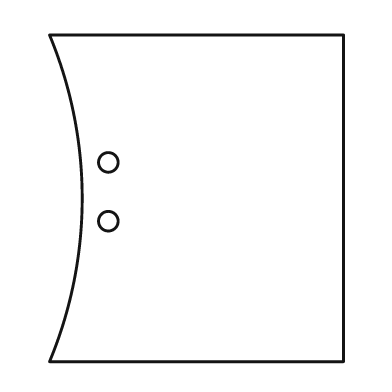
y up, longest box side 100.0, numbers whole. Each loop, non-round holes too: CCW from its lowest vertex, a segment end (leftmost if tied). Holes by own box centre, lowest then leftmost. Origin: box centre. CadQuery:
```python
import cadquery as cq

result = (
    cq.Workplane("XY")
    .moveTo(-45.0, -50.0)
    .lineTo(45.0, -50.0)
    .lineTo(45.0, 50.0)
    .lineTo(-45.0, 50.0)
    .threePointArc((-35.0, 0.0), (-45.0, -50.0))
    .close()
    .moveTo(-27.0, -7.0)
    .circle(3.0)
    .moveTo(-27.0, 11.0)
    .circle(3.0)
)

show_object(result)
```